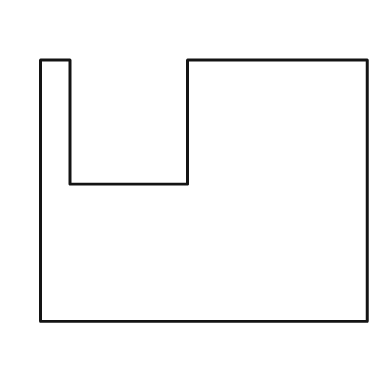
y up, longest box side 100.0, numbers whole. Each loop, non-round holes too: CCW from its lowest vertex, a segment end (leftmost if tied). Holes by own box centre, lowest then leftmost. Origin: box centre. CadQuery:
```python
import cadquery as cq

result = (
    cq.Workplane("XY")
    .moveTo(-50.0, -40.0)
    .lineTo(50.0, -40.0)
    .lineTo(50.0, 40.0)
    .lineTo(-5.0, 40.0)
    .lineTo(-5.0, 2.0)
    .lineTo(-41.0, 2.0)
    .lineTo(-41.0, 40.0)
    .lineTo(-50.0, 40.0)
    .close()
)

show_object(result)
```